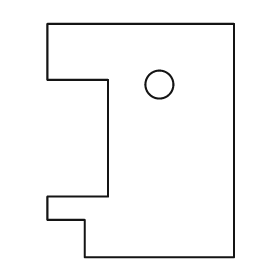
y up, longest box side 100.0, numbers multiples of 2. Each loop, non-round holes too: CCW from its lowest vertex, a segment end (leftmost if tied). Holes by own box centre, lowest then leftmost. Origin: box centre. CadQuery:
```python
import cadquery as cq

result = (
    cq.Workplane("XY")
    .moveTo(-24.0, -50.0)
    .lineTo(40.0, -50.0)
    .lineTo(40.0, 50.0)
    .lineTo(-40.0, 50.0)
    .lineTo(-40.0, 26.0)
    .lineTo(-14.0, 26.0)
    .lineTo(-14.0, -24.0)
    .lineTo(-40.0, -24.0)
    .lineTo(-40.0, -34.0)
    .lineTo(-24.0, -34.0)
    .close()
    .moveTo(8.0, 24.0)
    .circle(6.0)
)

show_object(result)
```